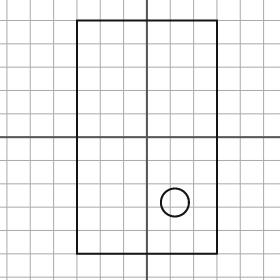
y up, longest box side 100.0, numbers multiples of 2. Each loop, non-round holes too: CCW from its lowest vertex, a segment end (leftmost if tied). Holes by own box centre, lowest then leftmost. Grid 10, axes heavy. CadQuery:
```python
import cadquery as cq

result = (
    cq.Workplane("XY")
    .moveTo(-30.0, -50.0)
    .lineTo(30.0, -50.0)
    .lineTo(30.0, 50.0)
    .lineTo(-30.0, 50.0)
    .close()
    .moveTo(12.0, -28.0)
    .circle(6.0)
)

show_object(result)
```